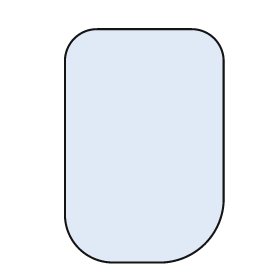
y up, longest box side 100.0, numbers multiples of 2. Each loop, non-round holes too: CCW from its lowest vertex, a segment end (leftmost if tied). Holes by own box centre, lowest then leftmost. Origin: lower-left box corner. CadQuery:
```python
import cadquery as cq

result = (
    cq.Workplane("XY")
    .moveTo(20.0, 0.0)
    .lineTo(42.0, 0.0)
    .threePointArc((60.0, 8.0), (68.0, 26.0))
    .lineTo(68.0, 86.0)
    .threePointArc((64.0, 96.0), (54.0, 100.0))
    .lineTo(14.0, 100.0)
    .threePointArc((4.0, 96.0), (0.0, 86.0))
    .lineTo(0.0, 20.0)
    .threePointArc((6.0, 6.0), (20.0, 0.0))
    .close()
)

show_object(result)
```